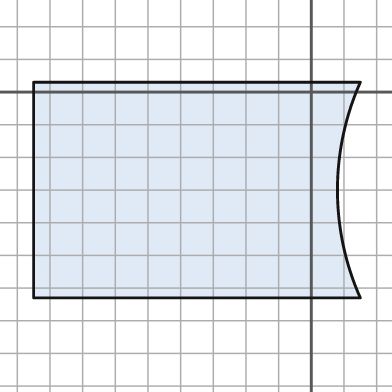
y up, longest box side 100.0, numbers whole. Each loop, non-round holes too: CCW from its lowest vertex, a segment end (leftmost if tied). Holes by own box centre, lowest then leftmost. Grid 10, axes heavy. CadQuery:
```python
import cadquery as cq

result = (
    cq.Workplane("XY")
    .moveTo(-85.0, -63.0)
    .lineTo(15.0, -63.0)
    .threePointArc((8.0, -30.0), (15.0, 3.0))
    .lineTo(-85.0, 3.0)
    .close()
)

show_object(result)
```